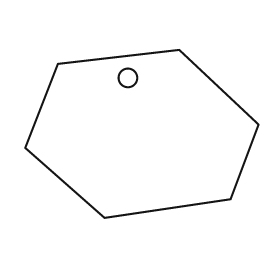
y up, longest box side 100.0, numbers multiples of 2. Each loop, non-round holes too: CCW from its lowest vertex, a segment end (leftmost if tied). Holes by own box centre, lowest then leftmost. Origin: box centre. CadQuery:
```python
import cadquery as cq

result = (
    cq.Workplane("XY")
    .moveTo(-16.0, -36.0)
    .lineTo(38.0, -28.0)
    .lineTo(50.0, 4.0)
    .lineTo(16.0, 36.0)
    .lineTo(-36.0, 30.0)
    .lineTo(-50.0, -6.0)
    .close()
    .moveTo(-6.0, 24.0)
    .circle(4.0)
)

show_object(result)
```